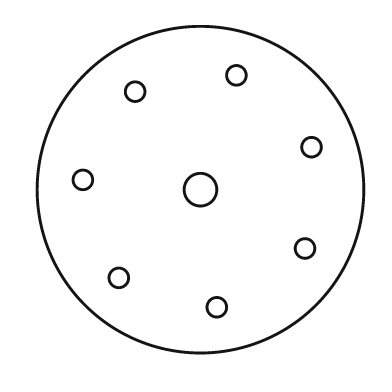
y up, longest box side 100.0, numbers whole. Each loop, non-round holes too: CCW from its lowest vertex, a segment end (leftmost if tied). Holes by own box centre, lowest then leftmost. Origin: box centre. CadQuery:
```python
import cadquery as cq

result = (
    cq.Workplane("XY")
    .moveTo(0.0, 0.0)
    .circle(50.0)
    .moveTo(5.0, -36.0)
    .circle(3.0)
    .moveTo(-25.0, -27.0)
    .circle(3.0)
    .moveTo(32.0, -18.0)
    .circle(3.0)
    .moveTo(0.0, 0.0)
    .circle(5.0)
    .moveTo(-36.0, 3.0)
    .circle(3.0)
    .moveTo(34.0, 13.0)
    .circle(3.0)
    .moveTo(-20.0, 30.0)
    .circle(3.0)
    .moveTo(11.0, 35.0)
    .circle(3.0)
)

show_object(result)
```